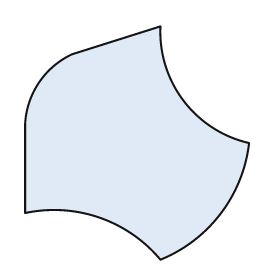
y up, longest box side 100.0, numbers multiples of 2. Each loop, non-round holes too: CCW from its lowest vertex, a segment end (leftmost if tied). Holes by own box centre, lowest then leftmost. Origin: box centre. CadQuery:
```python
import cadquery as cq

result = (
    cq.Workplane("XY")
    .moveTo(10.0, -50.0)
    .threePointArc((36.0, -30.0), (48.0, 0.0))
    .threePointArc((20.0, 18.0), (10.0, 50.0))
    .lineTo(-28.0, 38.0)
    .threePointArc((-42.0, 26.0), (-48.0, 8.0))
    .lineTo(-48.0, -30.0)
    .threePointArc((-16.0, -32.0), (10.0, -50.0))
    .close()
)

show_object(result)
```